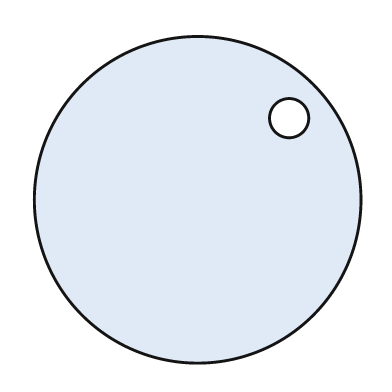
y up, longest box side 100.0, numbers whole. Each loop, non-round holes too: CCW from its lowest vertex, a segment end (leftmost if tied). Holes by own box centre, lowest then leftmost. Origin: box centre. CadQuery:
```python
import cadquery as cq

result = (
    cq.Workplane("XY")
    .moveTo(0.0, 0.0)
    .circle(50.0)
    .moveTo(28.0, 25.0)
    .circle(6.0)
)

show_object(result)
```